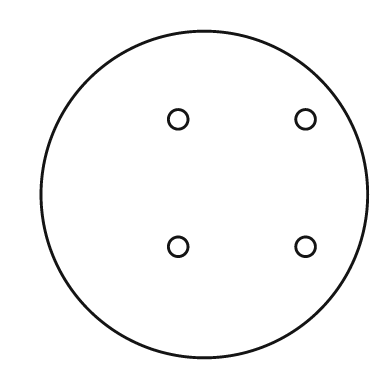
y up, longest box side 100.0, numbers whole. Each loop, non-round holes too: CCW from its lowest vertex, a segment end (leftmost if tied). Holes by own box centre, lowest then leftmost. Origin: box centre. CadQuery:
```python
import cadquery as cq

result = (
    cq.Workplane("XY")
    .moveTo(0.0, 0.0)
    .circle(50.0)
    .moveTo(-8.0, -16.0)
    .circle(3.0)
    .moveTo(31.0, -16.0)
    .circle(3.0)
    .moveTo(-8.0, 23.0)
    .circle(3.0)
    .moveTo(31.0, 23.0)
    .circle(3.0)
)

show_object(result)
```